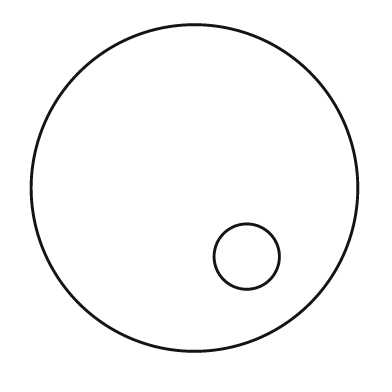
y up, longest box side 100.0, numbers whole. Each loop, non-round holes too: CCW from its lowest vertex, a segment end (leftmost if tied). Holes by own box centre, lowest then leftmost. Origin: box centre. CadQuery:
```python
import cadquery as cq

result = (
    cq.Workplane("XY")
    .moveTo(0.0, 0.0)
    .circle(50.0)
    .moveTo(16.0, -21.0)
    .circle(10.0)
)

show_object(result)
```